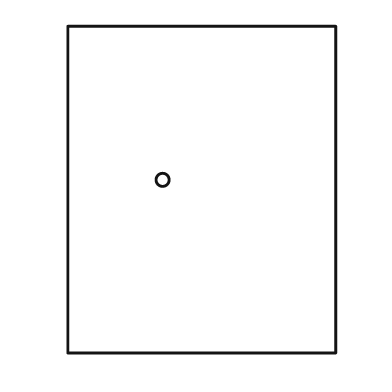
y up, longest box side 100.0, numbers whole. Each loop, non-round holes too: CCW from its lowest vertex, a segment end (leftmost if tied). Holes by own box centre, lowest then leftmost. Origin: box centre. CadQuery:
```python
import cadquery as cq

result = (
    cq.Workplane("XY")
    .moveTo(-41.0, -50.0)
    .lineTo(41.0, -50.0)
    .lineTo(41.0, 50.0)
    .lineTo(-41.0, 50.0)
    .close()
    .moveTo(-12.0, 3.0)
    .circle(2.0)
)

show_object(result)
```